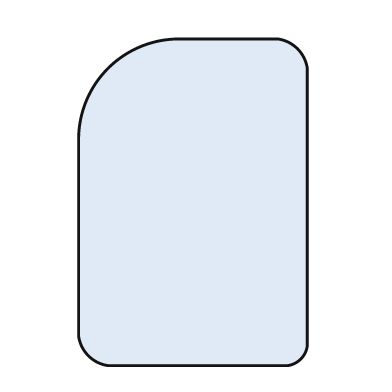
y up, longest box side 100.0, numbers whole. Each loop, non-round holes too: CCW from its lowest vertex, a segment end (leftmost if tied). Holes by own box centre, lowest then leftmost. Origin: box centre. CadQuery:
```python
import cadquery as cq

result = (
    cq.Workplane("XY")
    .moveTo(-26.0, -50.0)
    .lineTo(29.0, -50.0)
    .threePointArc((33.0, -48.0), (35.0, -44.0))
    .lineTo(35.0, 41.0)
    .threePointArc((32.0, 47.0), (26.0, 50.0))
    .lineTo(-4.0, 50.0)
    .threePointArc((-26.0, 41.0), (-35.0, 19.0))
    .lineTo(-35.0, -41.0)
    .threePointArc((-32.0, -47.0), (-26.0, -50.0))
    .close()
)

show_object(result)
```